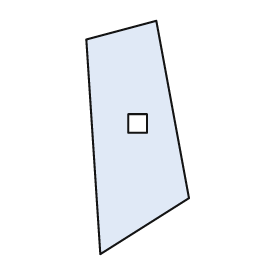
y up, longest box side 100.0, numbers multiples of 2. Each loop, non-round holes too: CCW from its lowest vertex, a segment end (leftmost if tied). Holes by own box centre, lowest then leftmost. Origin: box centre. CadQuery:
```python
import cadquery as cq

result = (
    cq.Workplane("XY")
    .moveTo(-16.0, -50.0)
    .lineTo(22.0, -26.0)
    .lineTo(8.0, 50.0)
    .lineTo(-22.0, 42.0)
    .close()
    .moveTo(-4.0, 2.0)
    .lineTo(4.0, 2.0)
    .lineTo(4.0, 10.0)
    .lineTo(-4.0, 10.0)
    .close()
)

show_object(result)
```